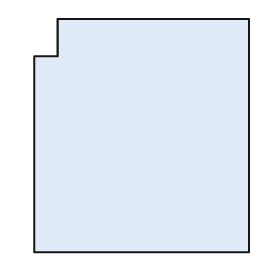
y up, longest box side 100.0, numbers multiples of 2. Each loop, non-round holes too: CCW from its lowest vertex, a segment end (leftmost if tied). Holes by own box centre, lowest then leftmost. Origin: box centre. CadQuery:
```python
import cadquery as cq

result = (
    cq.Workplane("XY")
    .moveTo(-46.0, -50.0)
    .lineTo(46.0, -50.0)
    .lineTo(46.0, 50.0)
    .lineTo(-36.0, 50.0)
    .lineTo(-36.0, 34.0)
    .lineTo(-46.0, 34.0)
    .close()
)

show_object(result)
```